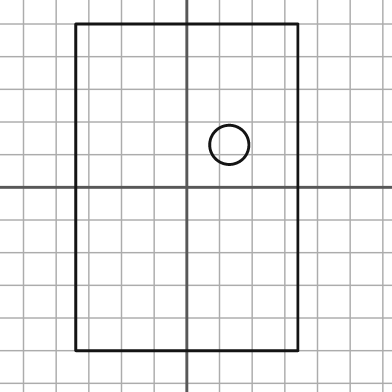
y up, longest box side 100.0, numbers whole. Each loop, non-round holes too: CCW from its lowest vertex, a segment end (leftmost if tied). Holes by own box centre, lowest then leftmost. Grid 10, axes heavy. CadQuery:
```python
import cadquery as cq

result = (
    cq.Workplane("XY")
    .moveTo(-34.0, -50.0)
    .lineTo(34.0, -50.0)
    .lineTo(34.0, 50.0)
    .lineTo(-34.0, 50.0)
    .close()
    .moveTo(13.0, 13.0)
    .circle(6.0)
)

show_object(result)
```